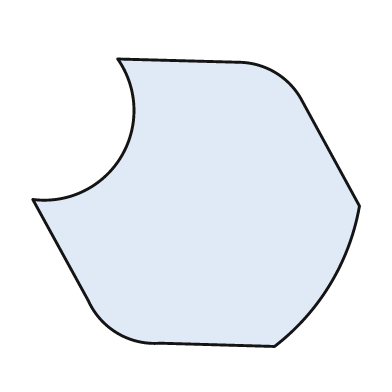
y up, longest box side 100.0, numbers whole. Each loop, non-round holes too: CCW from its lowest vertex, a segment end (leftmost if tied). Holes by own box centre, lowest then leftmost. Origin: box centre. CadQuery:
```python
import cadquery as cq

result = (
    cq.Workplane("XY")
    .moveTo(24.0, -44.0)
    .threePointArc((41.0, -25.0), (50.0, -1.0))
    .lineTo(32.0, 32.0)
    .threePointArc((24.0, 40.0), (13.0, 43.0))
    .lineTo(-24.0, 44.0)
    .threePointArc((-23.0, 14.0), (-50.0, 1.0))
    .lineTo(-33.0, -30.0)
    .threePointArc((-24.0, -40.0), (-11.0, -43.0))
    .close()
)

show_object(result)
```